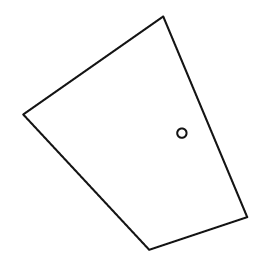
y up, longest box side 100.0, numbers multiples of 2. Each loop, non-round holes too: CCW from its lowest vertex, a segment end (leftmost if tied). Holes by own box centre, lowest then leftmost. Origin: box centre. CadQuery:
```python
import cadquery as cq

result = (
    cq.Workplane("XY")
    .moveTo(6.0, -50.0)
    .lineTo(48.0, -36.0)
    .lineTo(12.0, 50.0)
    .lineTo(-48.0, 8.0)
    .close()
    .moveTo(20.0, 0.0)
    .circle(2.0)
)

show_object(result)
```